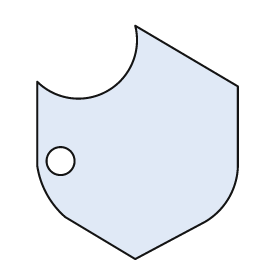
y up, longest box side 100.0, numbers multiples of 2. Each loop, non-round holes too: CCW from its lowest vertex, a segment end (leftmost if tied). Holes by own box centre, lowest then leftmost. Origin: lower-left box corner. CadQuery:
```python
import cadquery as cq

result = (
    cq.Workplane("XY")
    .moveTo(42.0, 0.0)
    .lineTo(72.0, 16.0)
    .threePointArc((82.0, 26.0), (86.0, 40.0))
    .lineTo(86.0, 74.0)
    .lineTo(42.0, 100.0)
    .threePointArc((30.0, 72.0), (0.0, 76.0))
    .lineTo(0.0, 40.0)
    .threePointArc((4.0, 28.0), (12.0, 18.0))
    .close()
    .moveTo(10.0, 42.0)
    .circle(6.0)
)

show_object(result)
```